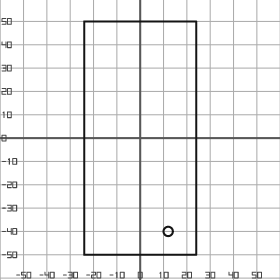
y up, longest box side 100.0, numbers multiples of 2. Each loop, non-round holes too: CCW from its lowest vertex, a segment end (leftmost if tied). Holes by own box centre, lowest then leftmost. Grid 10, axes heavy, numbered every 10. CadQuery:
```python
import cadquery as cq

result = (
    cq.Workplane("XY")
    .moveTo(-24.0, -50.0)
    .lineTo(24.0, -50.0)
    .lineTo(24.0, 50.0)
    .lineTo(-24.0, 50.0)
    .close()
    .moveTo(12.0, -40.0)
    .circle(2.0)
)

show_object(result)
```